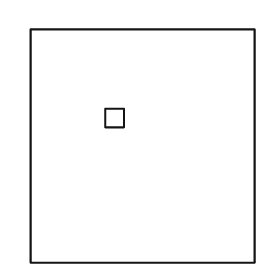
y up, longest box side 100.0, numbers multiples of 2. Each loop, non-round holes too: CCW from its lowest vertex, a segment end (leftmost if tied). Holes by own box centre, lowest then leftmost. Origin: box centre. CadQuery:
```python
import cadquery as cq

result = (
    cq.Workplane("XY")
    .moveTo(-48.0, -50.0)
    .lineTo(48.0, -50.0)
    .lineTo(48.0, 50.0)
    .lineTo(-48.0, 50.0)
    .close()
    .moveTo(-16.0, 8.0)
    .lineTo(-8.0, 8.0)
    .lineTo(-8.0, 16.0)
    .lineTo(-16.0, 16.0)
    .close()
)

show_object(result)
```